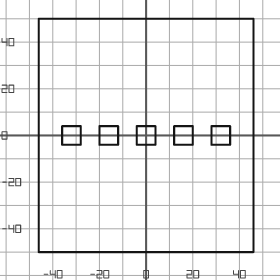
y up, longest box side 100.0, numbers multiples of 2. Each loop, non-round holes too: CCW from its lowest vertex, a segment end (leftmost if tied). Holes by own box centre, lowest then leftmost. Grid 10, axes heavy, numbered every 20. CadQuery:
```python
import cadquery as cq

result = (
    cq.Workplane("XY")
    .moveTo(-46.0, -50.0)
    .lineTo(46.0, -50.0)
    .lineTo(46.0, 50.0)
    .lineTo(-46.0, 50.0)
    .close()
    .moveTo(-36.0, -4.0)
    .lineTo(-28.0, -4.0)
    .lineTo(-28.0, 4.0)
    .lineTo(-36.0, 4.0)
    .close()
    .moveTo(-20.0, -4.0)
    .lineTo(-12.0, -4.0)
    .lineTo(-12.0, 4.0)
    .lineTo(-20.0, 4.0)
    .close()
    .moveTo(-4.0, -4.0)
    .lineTo(4.0, -4.0)
    .lineTo(4.0, 4.0)
    .lineTo(-4.0, 4.0)
    .close()
    .moveTo(12.0, -4.0)
    .lineTo(20.0, -4.0)
    .lineTo(20.0, 4.0)
    .lineTo(12.0, 4.0)
    .close()
    .moveTo(28.0, -4.0)
    .lineTo(36.0, -4.0)
    .lineTo(36.0, 4.0)
    .lineTo(28.0, 4.0)
    .close()
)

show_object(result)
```